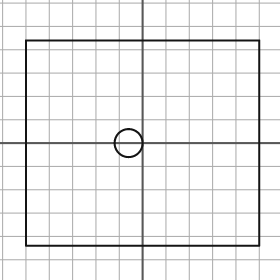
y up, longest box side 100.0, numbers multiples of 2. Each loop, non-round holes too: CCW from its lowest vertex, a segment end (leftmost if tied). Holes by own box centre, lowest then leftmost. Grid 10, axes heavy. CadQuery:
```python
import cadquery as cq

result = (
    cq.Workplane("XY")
    .moveTo(-50.0, -44.0)
    .lineTo(50.0, -44.0)
    .lineTo(50.0, 44.0)
    .lineTo(-50.0, 44.0)
    .close()
    .moveTo(-6.0, 0.0)
    .circle(6.0)
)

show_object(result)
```